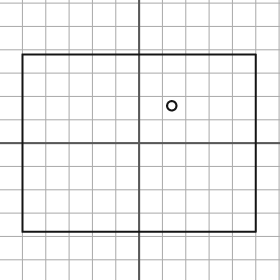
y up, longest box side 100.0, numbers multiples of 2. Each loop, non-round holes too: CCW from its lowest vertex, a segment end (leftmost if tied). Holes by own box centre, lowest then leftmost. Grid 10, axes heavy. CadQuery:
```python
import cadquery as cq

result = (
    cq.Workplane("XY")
    .moveTo(-50.0, -38.0)
    .lineTo(50.0, -38.0)
    .lineTo(50.0, 38.0)
    .lineTo(-50.0, 38.0)
    .close()
    .moveTo(14.0, 16.0)
    .circle(2.0)
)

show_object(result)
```